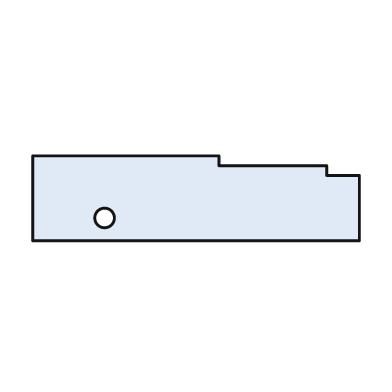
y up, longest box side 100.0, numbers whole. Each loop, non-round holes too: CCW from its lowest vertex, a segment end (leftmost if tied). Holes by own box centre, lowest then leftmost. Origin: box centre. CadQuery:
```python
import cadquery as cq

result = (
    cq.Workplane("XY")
    .moveTo(-50.0, -13.0)
    .lineTo(50.0, -13.0)
    .lineTo(50.0, 7.0)
    .lineTo(40.0, 7.0)
    .lineTo(40.0, 10.0)
    .lineTo(7.0, 10.0)
    .lineTo(7.0, 13.0)
    .lineTo(-50.0, 13.0)
    .close()
    .moveTo(-28.0, -6.0)
    .circle(3.0)
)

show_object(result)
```